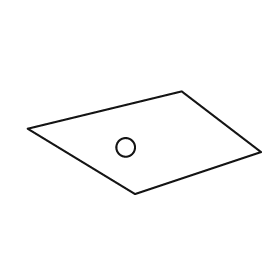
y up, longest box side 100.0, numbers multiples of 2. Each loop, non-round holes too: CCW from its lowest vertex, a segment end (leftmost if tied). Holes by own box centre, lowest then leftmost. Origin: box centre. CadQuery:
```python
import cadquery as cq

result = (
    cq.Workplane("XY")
    .moveTo(-4.0, -22.0)
    .lineTo(50.0, -4.0)
    .lineTo(16.0, 22.0)
    .lineTo(-50.0, 6.0)
    .close()
    .moveTo(-8.0, -2.0)
    .circle(4.0)
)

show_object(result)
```